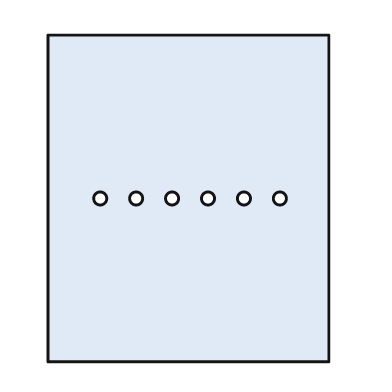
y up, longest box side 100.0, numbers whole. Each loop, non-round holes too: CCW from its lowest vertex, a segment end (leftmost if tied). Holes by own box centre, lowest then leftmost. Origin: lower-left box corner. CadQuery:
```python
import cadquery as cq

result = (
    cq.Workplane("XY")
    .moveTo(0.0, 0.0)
    .lineTo(86.0, 0.0)
    .lineTo(86.0, 100.0)
    .lineTo(0.0, 100.0)
    .close()
    .moveTo(16.0, 50.0)
    .circle(2.0)
    .moveTo(27.0, 50.0)
    .circle(2.0)
    .moveTo(38.0, 50.0)
    .circle(2.0)
    .moveTo(49.0, 50.0)
    .circle(2.0)
    .moveTo(60.0, 50.0)
    .circle(2.0)
    .moveTo(71.0, 50.0)
    .circle(2.0)
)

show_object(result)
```